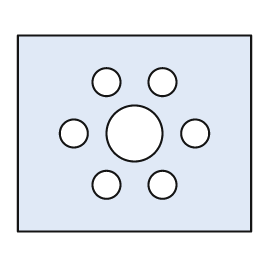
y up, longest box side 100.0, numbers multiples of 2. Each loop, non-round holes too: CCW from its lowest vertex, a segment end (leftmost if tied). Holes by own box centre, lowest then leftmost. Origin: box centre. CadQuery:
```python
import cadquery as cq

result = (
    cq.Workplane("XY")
    .moveTo(-50.0, -42.0)
    .lineTo(50.0, -42.0)
    .lineTo(50.0, 42.0)
    .lineTo(-50.0, 42.0)
    .close()
    .moveTo(-12.0, -22.0)
    .circle(6.0)
    .moveTo(12.0, -22.0)
    .circle(6.0)
    .moveTo(-26.0, 0.0)
    .circle(6.0)
    .moveTo(0.0, 0.0)
    .circle(12.0)
    .moveTo(26.0, 0.0)
    .circle(6.0)
    .moveTo(-12.0, 22.0)
    .circle(6.0)
    .moveTo(12.0, 22.0)
    .circle(6.0)
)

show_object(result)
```